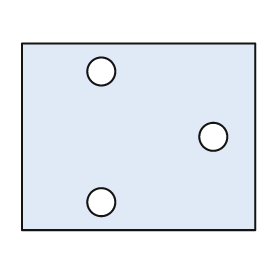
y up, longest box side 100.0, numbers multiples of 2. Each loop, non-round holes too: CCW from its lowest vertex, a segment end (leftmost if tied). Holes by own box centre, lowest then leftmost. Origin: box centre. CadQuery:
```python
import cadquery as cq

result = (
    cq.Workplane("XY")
    .moveTo(-50.0, -40.0)
    .lineTo(50.0, -40.0)
    .lineTo(50.0, 40.0)
    .lineTo(-50.0, 40.0)
    .close()
    .moveTo(-16.0, -28.0)
    .circle(6.0)
    .moveTo(32.0, 0.0)
    .circle(6.0)
    .moveTo(-16.0, 28.0)
    .circle(6.0)
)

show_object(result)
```